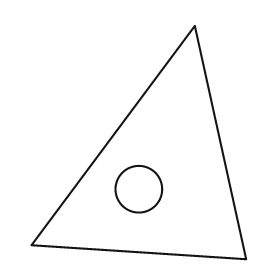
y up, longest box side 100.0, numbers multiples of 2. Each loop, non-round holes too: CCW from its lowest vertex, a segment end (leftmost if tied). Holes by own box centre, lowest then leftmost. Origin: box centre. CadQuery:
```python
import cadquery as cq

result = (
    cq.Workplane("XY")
    .moveTo(46.0, -50.0)
    .lineTo(24.0, 50.0)
    .lineTo(-46.0, -44.0)
    .close()
    .moveTo(0.0, -20.0)
    .circle(10.0)
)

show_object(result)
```